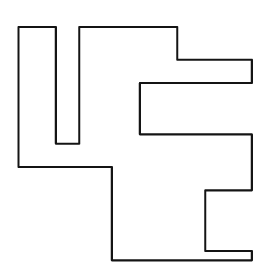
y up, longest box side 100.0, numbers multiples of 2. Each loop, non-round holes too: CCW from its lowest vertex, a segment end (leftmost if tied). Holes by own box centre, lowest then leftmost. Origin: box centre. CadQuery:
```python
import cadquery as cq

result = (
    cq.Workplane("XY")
    .moveTo(-10.0, -50.0)
    .lineTo(50.0, -50.0)
    .lineTo(50.0, -46.0)
    .lineTo(30.0, -46.0)
    .lineTo(30.0, -20.0)
    .lineTo(50.0, -20.0)
    .lineTo(50.0, 4.0)
    .lineTo(2.0, 4.0)
    .lineTo(2.0, 26.0)
    .lineTo(50.0, 26.0)
    .lineTo(50.0, 36.0)
    .lineTo(18.0, 36.0)
    .lineTo(18.0, 50.0)
    .lineTo(-24.0, 50.0)
    .lineTo(-24.0, 0.0)
    .lineTo(-34.0, 0.0)
    .lineTo(-34.0, 50.0)
    .lineTo(-50.0, 50.0)
    .lineTo(-50.0, -10.0)
    .lineTo(-10.0, -10.0)
    .close()
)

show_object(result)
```